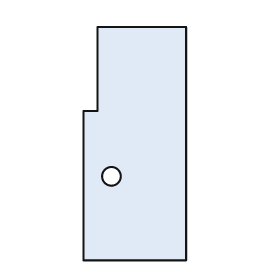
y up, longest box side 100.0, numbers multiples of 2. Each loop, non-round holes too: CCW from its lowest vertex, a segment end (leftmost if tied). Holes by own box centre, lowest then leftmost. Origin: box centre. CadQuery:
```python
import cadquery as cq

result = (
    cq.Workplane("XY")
    .moveTo(-22.0, -50.0)
    .lineTo(22.0, -50.0)
    .lineTo(22.0, 50.0)
    .lineTo(-16.0, 50.0)
    .lineTo(-16.0, 14.0)
    .lineTo(-22.0, 14.0)
    .close()
    .moveTo(-10.0, -14.0)
    .circle(4.0)
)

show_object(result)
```